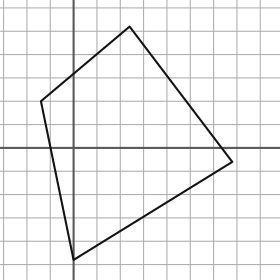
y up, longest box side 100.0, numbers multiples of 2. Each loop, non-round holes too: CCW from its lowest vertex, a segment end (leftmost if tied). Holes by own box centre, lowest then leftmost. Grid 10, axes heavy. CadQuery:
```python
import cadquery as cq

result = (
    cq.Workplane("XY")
    .moveTo(0.0, -48.0)
    .lineTo(68.0, -6.0)
    .lineTo(24.0, 52.0)
    .lineTo(-14.0, 20.0)
    .close()
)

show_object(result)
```